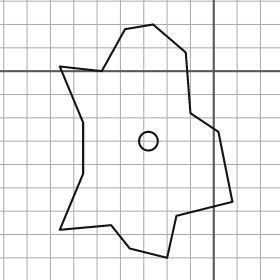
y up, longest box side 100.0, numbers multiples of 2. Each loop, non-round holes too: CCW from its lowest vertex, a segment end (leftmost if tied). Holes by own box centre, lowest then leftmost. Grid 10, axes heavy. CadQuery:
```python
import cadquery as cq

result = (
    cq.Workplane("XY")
    .moveTo(-20.0, -80.0)
    .lineTo(-16.0, -62.0)
    .lineTo(8.0, -56.0)
    .lineTo(2.0, -26.0)
    .lineTo(-10.0, -18.0)
    .lineTo(-12.0, 8.0)
    .lineTo(-26.0, 20.0)
    .lineTo(-38.0, 18.0)
    .lineTo(-48.0, 0.0)
    .lineTo(-66.0, 2.0)
    .lineTo(-56.0, -22.0)
    .lineTo(-56.0, -44.0)
    .lineTo(-66.0, -68.0)
    .lineTo(-44.0, -66.0)
    .lineTo(-36.0, -76.0)
    .close()
    .moveTo(-28.0, -30.0)
    .circle(4.0)
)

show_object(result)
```